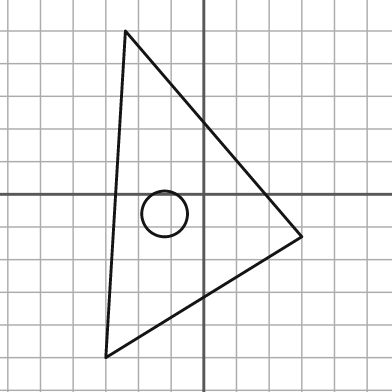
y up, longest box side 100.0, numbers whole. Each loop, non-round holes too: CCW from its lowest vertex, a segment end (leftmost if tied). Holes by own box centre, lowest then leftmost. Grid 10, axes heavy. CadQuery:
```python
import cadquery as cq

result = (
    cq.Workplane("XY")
    .moveTo(-30.0, -50.0)
    .lineTo(30.0, -13.0)
    .lineTo(-24.0, 50.0)
    .close()
    .moveTo(-12.0, -6.0)
    .circle(7.0)
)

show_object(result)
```